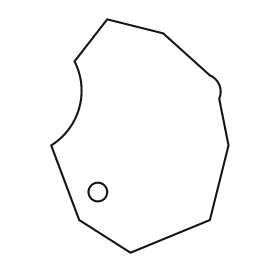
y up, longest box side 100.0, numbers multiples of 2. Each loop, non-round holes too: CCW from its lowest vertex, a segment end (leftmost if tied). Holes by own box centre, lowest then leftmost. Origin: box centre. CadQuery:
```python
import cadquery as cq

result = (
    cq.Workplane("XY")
    .moveTo(-4.0, -50.0)
    .lineTo(30.0, -36.0)
    .lineTo(38.0, -4.0)
    .lineTo(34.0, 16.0)
    .threePointArc((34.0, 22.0), (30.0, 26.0))
    .lineTo(10.0, 44.0)
    .lineTo(-14.0, 50.0)
    .lineTo(-28.0, 32.0)
    .threePointArc((-26.0, 12.0), (-38.0, -4.0))
    .lineTo(-26.0, -36.0)
    .close()
    .moveTo(-18.0, -24.0)
    .circle(4.0)
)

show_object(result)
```